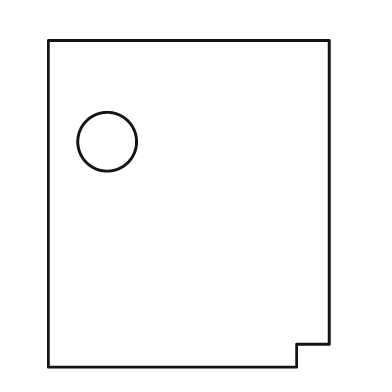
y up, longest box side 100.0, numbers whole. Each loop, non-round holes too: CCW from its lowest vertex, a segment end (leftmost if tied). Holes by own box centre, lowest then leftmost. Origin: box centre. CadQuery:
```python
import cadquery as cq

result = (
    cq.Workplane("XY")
    .moveTo(-43.0, -50.0)
    .lineTo(33.0, -50.0)
    .lineTo(33.0, -43.0)
    .lineTo(43.0, -43.0)
    .lineTo(43.0, 50.0)
    .lineTo(-43.0, 50.0)
    .close()
    .moveTo(-25.0, 19.0)
    .circle(9.0)
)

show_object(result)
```